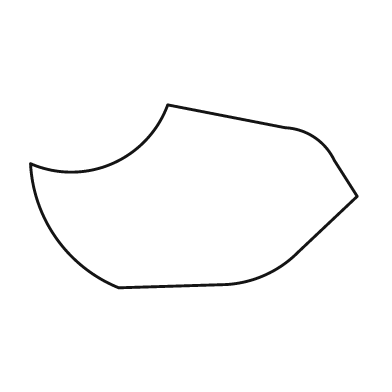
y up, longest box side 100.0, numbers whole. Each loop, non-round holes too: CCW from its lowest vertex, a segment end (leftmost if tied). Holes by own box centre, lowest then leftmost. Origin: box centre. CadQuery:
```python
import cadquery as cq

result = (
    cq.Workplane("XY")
    .moveTo(-23.0, -28.0)
    .lineTo(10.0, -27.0)
    .threePointArc((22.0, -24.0), (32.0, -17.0))
    .lineTo(50.0, 0.0)
    .lineTo(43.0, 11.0)
    .threePointArc((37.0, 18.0), (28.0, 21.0))
    .lineTo(-8.0, 28.0)
    .threePointArc((-25.0, 10.0), (-50.0, 10.0))
    .threePointArc((-42.0, -13.0), (-23.0, -28.0))
    .close()
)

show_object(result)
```